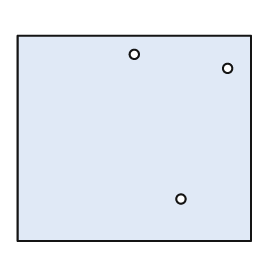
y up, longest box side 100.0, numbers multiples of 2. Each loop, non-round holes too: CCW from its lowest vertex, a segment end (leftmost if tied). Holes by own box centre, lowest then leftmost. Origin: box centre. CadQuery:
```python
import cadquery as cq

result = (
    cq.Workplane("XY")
    .moveTo(-50.0, -44.0)
    .lineTo(50.0, -44.0)
    .lineTo(50.0, 44.0)
    .lineTo(-50.0, 44.0)
    .close()
    .moveTo(20.0, -26.0)
    .circle(2.0)
    .moveTo(40.0, 30.0)
    .circle(2.0)
    .moveTo(0.0, 36.0)
    .circle(2.0)
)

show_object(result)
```